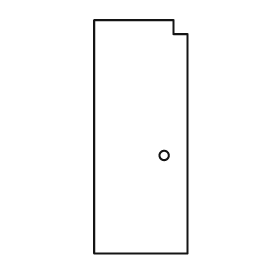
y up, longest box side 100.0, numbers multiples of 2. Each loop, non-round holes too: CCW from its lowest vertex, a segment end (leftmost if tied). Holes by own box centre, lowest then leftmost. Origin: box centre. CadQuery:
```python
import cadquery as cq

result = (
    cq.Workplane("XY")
    .moveTo(-20.0, -50.0)
    .lineTo(20.0, -50.0)
    .lineTo(20.0, 44.0)
    .lineTo(14.0, 44.0)
    .lineTo(14.0, 50.0)
    .lineTo(-20.0, 50.0)
    .close()
    .moveTo(10.0, -8.0)
    .circle(2.0)
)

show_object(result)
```